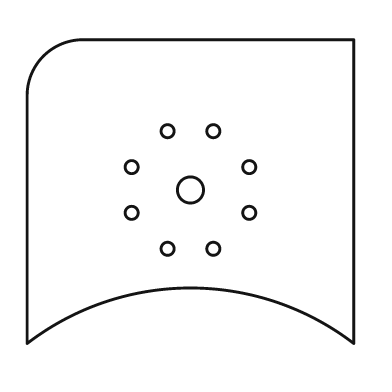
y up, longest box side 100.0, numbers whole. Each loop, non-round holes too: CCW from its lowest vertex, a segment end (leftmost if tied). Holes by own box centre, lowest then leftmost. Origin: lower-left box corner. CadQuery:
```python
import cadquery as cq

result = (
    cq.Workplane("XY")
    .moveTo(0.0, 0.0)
    .threePointArc((50.0, 17.0), (100.0, 0.0))
    .lineTo(100.0, 93.0)
    .lineTo(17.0, 93.0)
    .threePointArc((5.0, 88.0), (0.0, 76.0))
    .close()
    .moveTo(43.0, 29.0)
    .circle(2.0)
    .moveTo(57.0, 29.0)
    .circle(2.0)
    .moveTo(32.0, 40.0)
    .circle(2.0)
    .moveTo(68.0, 40.0)
    .circle(2.0)
    .moveTo(50.0, 47.0)
    .circle(4.0)
    .moveTo(32.0, 54.0)
    .circle(2.0)
    .moveTo(68.0, 54.0)
    .circle(2.0)
    .moveTo(43.0, 65.0)
    .circle(2.0)
    .moveTo(57.0, 65.0)
    .circle(2.0)
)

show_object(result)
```